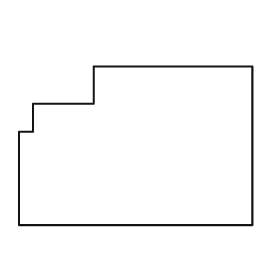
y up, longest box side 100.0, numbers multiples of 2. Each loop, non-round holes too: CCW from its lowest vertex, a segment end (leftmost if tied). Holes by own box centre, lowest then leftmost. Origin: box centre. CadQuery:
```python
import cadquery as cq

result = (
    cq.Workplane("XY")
    .moveTo(-50.0, -34.0)
    .lineTo(50.0, -34.0)
    .lineTo(50.0, 34.0)
    .lineTo(-18.0, 34.0)
    .lineTo(-18.0, 18.0)
    .lineTo(-44.0, 18.0)
    .lineTo(-44.0, 6.0)
    .lineTo(-50.0, 6.0)
    .close()
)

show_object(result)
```